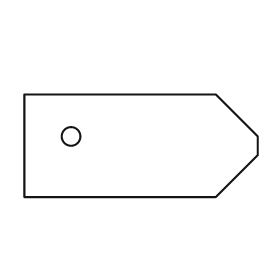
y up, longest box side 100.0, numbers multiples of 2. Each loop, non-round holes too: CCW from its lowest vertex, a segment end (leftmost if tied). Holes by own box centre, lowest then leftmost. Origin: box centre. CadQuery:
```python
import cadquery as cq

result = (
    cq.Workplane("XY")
    .moveTo(-50.0, -22.0)
    .lineTo(32.0, -22.0)
    .lineTo(50.0, -4.0)
    .lineTo(50.0, 4.0)
    .lineTo(32.0, 22.0)
    .lineTo(-50.0, 22.0)
    .close()
    .moveTo(-30.0, 4.0)
    .circle(4.0)
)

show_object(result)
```